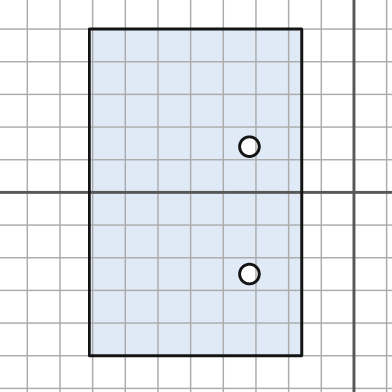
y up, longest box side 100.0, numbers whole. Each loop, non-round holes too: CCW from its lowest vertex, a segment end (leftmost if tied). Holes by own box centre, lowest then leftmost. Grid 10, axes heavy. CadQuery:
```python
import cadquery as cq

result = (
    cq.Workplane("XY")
    .moveTo(-81.0, -50.0)
    .lineTo(-16.0, -50.0)
    .lineTo(-16.0, 50.0)
    .lineTo(-81.0, 50.0)
    .close()
    .moveTo(-32.0, -25.0)
    .circle(3.0)
    .moveTo(-32.0, 14.0)
    .circle(3.0)
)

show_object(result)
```